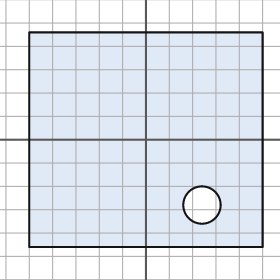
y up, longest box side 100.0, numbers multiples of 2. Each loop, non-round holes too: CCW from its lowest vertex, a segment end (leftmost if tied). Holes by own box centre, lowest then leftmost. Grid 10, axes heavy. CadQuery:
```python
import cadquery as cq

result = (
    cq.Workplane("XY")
    .moveTo(-50.0, -46.0)
    .lineTo(50.0, -46.0)
    .lineTo(50.0, 46.0)
    .lineTo(-50.0, 46.0)
    .close()
    .moveTo(24.0, -28.0)
    .circle(8.0)
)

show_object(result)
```